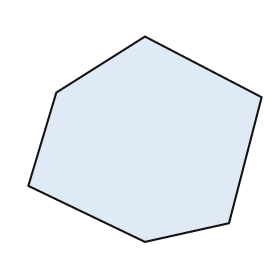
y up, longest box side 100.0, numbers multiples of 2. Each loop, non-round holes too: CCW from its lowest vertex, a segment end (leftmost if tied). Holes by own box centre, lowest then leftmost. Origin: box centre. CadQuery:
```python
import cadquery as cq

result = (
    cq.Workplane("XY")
    .moveTo(0.0, -44.0)
    .lineTo(36.0, -36.0)
    .lineTo(50.0, 18.0)
    .lineTo(0.0, 44.0)
    .lineTo(-38.0, 20.0)
    .lineTo(-50.0, -20.0)
    .close()
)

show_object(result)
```